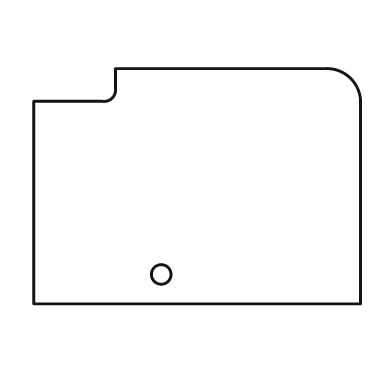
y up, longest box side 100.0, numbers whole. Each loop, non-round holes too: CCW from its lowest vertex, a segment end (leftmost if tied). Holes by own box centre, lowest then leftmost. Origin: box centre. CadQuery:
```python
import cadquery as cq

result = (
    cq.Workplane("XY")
    .moveTo(-50.0, -36.0)
    .lineTo(50.0, -36.0)
    .lineTo(50.0, 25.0)
    .threePointArc((47.0, 33.0), (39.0, 36.0))
    .lineTo(-25.0, 36.0)
    .lineTo(-25.0, 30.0)
    .threePointArc((-26.0, 27.0), (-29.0, 26.0))
    .lineTo(-50.0, 26.0)
    .close()
    .moveTo(-11.0, -27.0)
    .circle(3.0)
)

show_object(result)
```